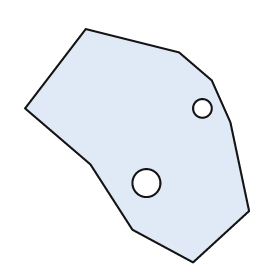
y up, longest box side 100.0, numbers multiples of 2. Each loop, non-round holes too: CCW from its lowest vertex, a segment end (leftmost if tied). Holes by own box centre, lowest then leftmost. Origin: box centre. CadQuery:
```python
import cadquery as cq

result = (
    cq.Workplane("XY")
    .moveTo(24.0, -50.0)
    .lineTo(48.0, -28.0)
    .lineTo(40.0, 10.0)
    .lineTo(32.0, 28.0)
    .lineTo(18.0, 40.0)
    .lineTo(-22.0, 50.0)
    .lineTo(-48.0, 16.0)
    .lineTo(-20.0, -8.0)
    .lineTo(-2.0, -36.0)
    .close()
    .moveTo(4.0, -16.0)
    .circle(6.0)
    .moveTo(28.0, 16.0)
    .circle(4.0)
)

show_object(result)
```